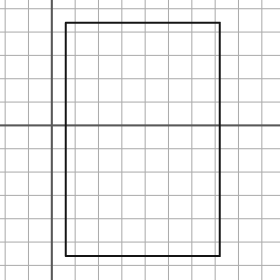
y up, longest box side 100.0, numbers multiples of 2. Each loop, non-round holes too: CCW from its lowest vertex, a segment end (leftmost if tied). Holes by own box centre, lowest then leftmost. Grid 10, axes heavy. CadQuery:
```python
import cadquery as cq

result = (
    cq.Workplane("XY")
    .moveTo(6.0, -56.0)
    .lineTo(72.0, -56.0)
    .lineTo(72.0, 44.0)
    .lineTo(6.0, 44.0)
    .close()
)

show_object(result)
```